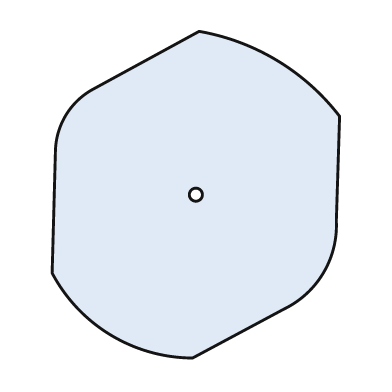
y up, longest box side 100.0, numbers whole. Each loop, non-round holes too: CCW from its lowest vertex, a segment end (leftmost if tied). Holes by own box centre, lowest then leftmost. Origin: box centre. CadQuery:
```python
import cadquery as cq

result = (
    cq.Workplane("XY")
    .moveTo(-1.0, -50.0)
    .lineTo(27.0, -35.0)
    .threePointArc((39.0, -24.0), (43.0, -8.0))
    .lineTo(44.0, 24.0)
    .threePointArc((25.0, 41.0), (1.0, 50.0))
    .lineTo(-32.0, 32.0)
    .threePointArc((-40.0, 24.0), (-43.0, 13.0))
    .lineTo(-44.0, -24.0)
    .threePointArc((-26.0, -43.0), (-1.0, -50.0))
    .close()
    .moveTo(0.0, 0.0)
    .circle(2.0)
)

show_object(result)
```